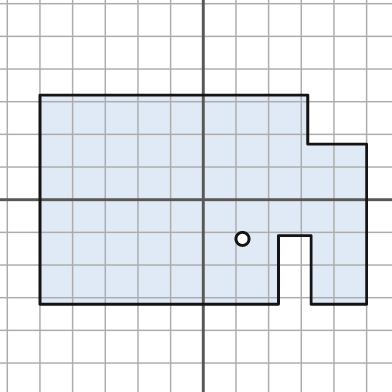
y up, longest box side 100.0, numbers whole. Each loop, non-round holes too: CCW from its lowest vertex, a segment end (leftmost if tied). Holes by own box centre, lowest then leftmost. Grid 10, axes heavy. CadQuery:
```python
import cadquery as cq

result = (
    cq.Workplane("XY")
    .moveTo(-50.0, -32.0)
    .lineTo(23.0, -32.0)
    .lineTo(23.0, -11.0)
    .lineTo(33.0, -11.0)
    .lineTo(33.0, -32.0)
    .lineTo(50.0, -32.0)
    .lineTo(50.0, 17.0)
    .lineTo(32.0, 17.0)
    .lineTo(32.0, 32.0)
    .lineTo(-50.0, 32.0)
    .close()
    .moveTo(12.0, -12.0)
    .circle(2.0)
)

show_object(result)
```